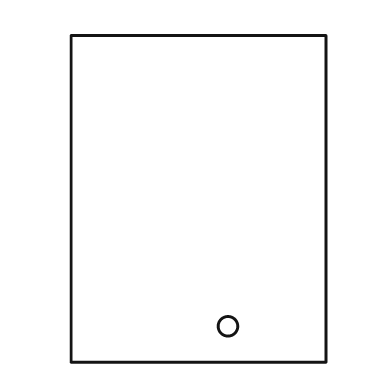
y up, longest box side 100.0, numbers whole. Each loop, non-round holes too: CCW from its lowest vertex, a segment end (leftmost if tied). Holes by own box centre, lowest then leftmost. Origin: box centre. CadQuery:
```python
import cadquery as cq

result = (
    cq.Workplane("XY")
    .moveTo(-39.0, -50.0)
    .lineTo(39.0, -50.0)
    .lineTo(39.0, 50.0)
    .lineTo(-39.0, 50.0)
    .close()
    .moveTo(9.0, -39.0)
    .circle(3.0)
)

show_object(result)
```